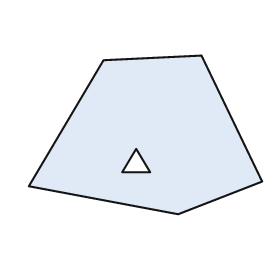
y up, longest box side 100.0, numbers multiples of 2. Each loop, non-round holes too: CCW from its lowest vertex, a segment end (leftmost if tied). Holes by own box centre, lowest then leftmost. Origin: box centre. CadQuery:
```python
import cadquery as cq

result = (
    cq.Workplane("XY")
    .moveTo(14.0, -34.0)
    .lineTo(50.0, -20.0)
    .lineTo(24.0, 34.0)
    .lineTo(-18.0, 32.0)
    .lineTo(-50.0, -22.0)
    .close()
    .moveTo(-10.0, -16.0)
    .lineTo(2.0, -16.0)
    .lineTo(-4.0, -6.0)
    .close()
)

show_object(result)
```